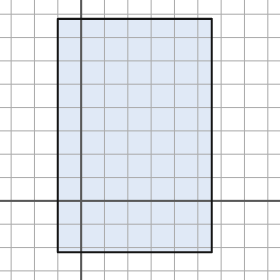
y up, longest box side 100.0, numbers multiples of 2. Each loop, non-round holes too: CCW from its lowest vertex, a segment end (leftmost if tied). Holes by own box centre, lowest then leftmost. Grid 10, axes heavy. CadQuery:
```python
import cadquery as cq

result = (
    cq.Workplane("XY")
    .moveTo(-10.0, -22.0)
    .lineTo(56.0, -22.0)
    .lineTo(56.0, 78.0)
    .lineTo(-10.0, 78.0)
    .close()
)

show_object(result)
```